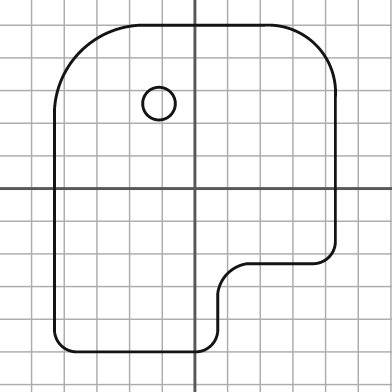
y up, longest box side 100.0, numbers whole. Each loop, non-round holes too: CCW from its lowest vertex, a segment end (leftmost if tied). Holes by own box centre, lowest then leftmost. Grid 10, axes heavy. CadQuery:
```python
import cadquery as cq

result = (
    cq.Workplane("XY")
    .moveTo(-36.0, -50.0)
    .lineTo(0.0, -50.0)
    .threePointArc((5.0, -48.0), (7.0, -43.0))
    .lineTo(7.0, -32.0)
    .threePointArc((10.0, -26.0), (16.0, -23.0))
    .lineTo(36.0, -23.0)
    .threePointArc((41.0, -21.0), (43.0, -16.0))
    .lineTo(43.0, 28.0)
    .threePointArc((37.0, 44.0), (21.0, 50.0))
    .lineTo(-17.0, 50.0)
    .threePointArc((-35.0, 42.0), (-43.0, 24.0))
    .lineTo(-43.0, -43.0)
    .threePointArc((-41.0, -48.0), (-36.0, -50.0))
    .close()
    .moveTo(-11.0, 26.0)
    .circle(5.0)
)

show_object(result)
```